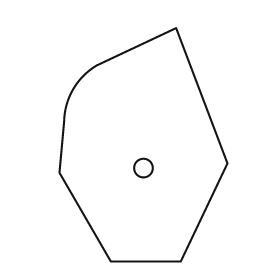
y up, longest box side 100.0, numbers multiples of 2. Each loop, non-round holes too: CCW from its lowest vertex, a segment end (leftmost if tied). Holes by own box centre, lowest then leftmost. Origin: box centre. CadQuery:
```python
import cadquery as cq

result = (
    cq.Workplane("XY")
    .moveTo(-14.0, -50.0)
    .lineTo(16.0, -50.0)
    .lineTo(36.0, -8.0)
    .lineTo(14.0, 50.0)
    .lineTo(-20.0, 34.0)
    .threePointArc((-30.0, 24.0), (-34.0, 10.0))
    .lineTo(-36.0, -12.0)
    .close()
    .moveTo(0.0, -10.0)
    .circle(4.0)
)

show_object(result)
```